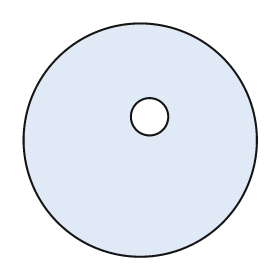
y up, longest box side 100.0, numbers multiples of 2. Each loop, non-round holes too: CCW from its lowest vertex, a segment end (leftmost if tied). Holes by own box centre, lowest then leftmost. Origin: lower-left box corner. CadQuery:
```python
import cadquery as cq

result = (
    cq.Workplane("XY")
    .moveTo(50.0, 50.0)
    .circle(50.0)
    .moveTo(54.0, 60.0)
    .circle(8.0)
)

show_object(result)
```